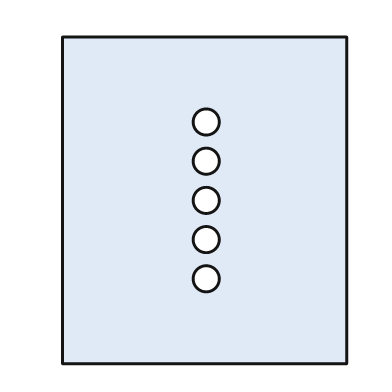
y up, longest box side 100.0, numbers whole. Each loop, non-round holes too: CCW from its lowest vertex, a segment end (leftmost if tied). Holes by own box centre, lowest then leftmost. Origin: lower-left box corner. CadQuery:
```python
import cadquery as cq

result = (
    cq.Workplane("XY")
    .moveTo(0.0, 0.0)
    .lineTo(87.0, 0.0)
    .lineTo(87.0, 100.0)
    .lineTo(0.0, 100.0)
    .close()
    .moveTo(44.0, 26.0)
    .circle(4.0)
    .moveTo(44.0, 38.0)
    .circle(4.0)
    .moveTo(44.0, 50.0)
    .circle(4.0)
    .moveTo(44.0, 62.0)
    .circle(4.0)
    .moveTo(44.0, 74.0)
    .circle(4.0)
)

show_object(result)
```